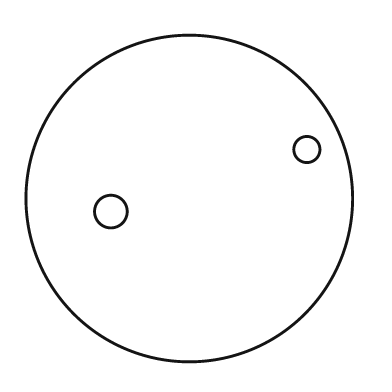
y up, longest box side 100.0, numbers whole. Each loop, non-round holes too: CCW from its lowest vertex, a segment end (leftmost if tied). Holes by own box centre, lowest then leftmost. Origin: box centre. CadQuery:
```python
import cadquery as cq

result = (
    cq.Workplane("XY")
    .moveTo(0.0, 0.0)
    .circle(50.0)
    .moveTo(-24.0, -4.0)
    .circle(5.0)
    .moveTo(36.0, 15.0)
    .circle(4.0)
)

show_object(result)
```